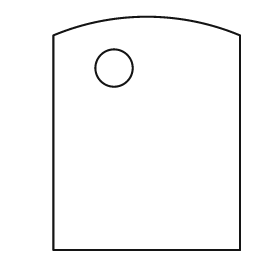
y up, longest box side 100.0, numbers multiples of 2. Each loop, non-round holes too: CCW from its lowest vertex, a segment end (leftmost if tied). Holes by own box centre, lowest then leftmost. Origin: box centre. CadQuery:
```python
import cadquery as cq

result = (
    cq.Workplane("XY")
    .moveTo(-40.0, -50.0)
    .lineTo(40.0, -50.0)
    .lineTo(40.0, 42.0)
    .threePointArc((0.0, 50.0), (-40.0, 42.0))
    .close()
    .moveTo(-14.0, 28.0)
    .circle(8.0)
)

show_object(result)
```